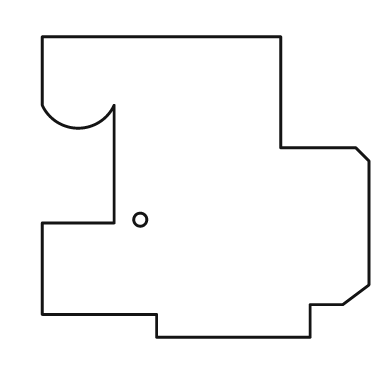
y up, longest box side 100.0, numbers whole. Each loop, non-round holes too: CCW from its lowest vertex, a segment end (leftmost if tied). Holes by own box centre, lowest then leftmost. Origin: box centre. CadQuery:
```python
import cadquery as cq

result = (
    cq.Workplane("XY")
    .moveTo(-15.0, -46.0)
    .lineTo(32.0, -46.0)
    .lineTo(32.0, -36.0)
    .lineTo(42.0, -36.0)
    .lineTo(50.0, -30.0)
    .lineTo(50.0, 8.0)
    .lineTo(46.0, 12.0)
    .lineTo(23.0, 12.0)
    .lineTo(23.0, 46.0)
    .lineTo(-50.0, 46.0)
    .lineTo(-50.0, 25.0)
    .threePointArc((-39.0, 18.0), (-28.0, 25.0))
    .lineTo(-28.0, -11.0)
    .lineTo(-50.0, -11.0)
    .lineTo(-50.0, -39.0)
    .lineTo(-15.0, -39.0)
    .close()
    .moveTo(-20.0, -10.0)
    .circle(2.0)
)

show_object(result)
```